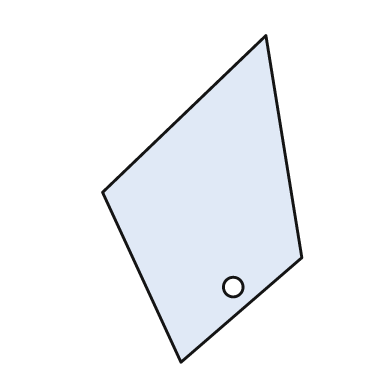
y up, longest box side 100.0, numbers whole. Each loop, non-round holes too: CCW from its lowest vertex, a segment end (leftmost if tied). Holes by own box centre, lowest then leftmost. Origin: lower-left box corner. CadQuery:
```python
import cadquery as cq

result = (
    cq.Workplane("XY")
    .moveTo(24.0, 0.0)
    .lineTo(61.0, 32.0)
    .lineTo(50.0, 100.0)
    .lineTo(0.0, 52.0)
    .close()
    .moveTo(40.0, 23.0)
    .circle(3.0)
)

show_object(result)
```